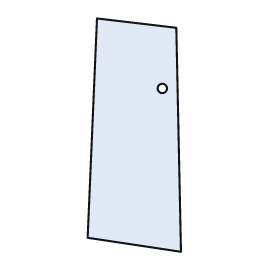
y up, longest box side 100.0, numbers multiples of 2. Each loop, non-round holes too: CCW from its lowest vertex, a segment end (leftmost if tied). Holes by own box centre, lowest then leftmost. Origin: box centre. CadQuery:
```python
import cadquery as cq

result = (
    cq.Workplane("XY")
    .moveTo(20.0, -50.0)
    .lineTo(18.0, 46.0)
    .lineTo(-16.0, 50.0)
    .lineTo(-20.0, -44.0)
    .close()
    .moveTo(12.0, 20.0)
    .circle(2.0)
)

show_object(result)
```